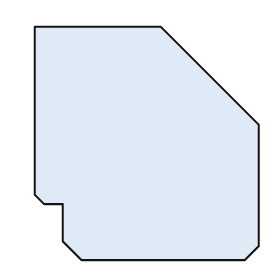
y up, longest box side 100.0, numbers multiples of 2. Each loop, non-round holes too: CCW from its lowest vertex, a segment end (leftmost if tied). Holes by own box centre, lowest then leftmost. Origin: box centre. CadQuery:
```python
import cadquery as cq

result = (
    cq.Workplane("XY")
    .moveTo(-28.0, -50.0)
    .lineTo(42.0, -50.0)
    .lineTo(48.0, -44.0)
    .lineTo(48.0, 8.0)
    .lineTo(6.0, 50.0)
    .lineTo(-48.0, 50.0)
    .lineTo(-48.0, -22.0)
    .lineTo(-44.0, -26.0)
    .lineTo(-36.0, -26.0)
    .lineTo(-36.0, -42.0)
    .close()
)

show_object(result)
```